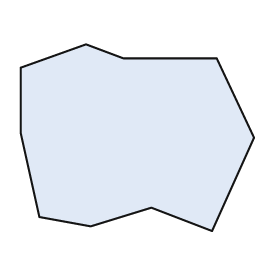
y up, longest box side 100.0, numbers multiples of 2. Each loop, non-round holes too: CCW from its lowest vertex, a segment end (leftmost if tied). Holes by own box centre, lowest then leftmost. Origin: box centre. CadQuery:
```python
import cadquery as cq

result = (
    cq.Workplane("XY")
    .moveTo(32.0, -40.0)
    .lineTo(50.0, 0.0)
    .lineTo(34.0, 34.0)
    .lineTo(-6.0, 34.0)
    .lineTo(-22.0, 40.0)
    .lineTo(-50.0, 30.0)
    .lineTo(-50.0, 2.0)
    .lineTo(-42.0, -34.0)
    .lineTo(-20.0, -38.0)
    .lineTo(6.0, -30.0)
    .close()
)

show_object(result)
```